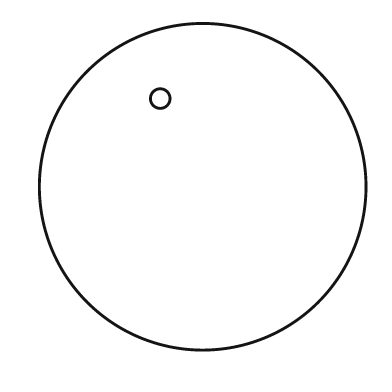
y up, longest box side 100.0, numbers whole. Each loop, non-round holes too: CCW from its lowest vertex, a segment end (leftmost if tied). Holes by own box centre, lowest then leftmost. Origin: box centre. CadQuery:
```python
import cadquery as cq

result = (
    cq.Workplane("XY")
    .moveTo(0.0, 0.0)
    .circle(50.0)
    .moveTo(-13.0, 27.0)
    .circle(3.0)
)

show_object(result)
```